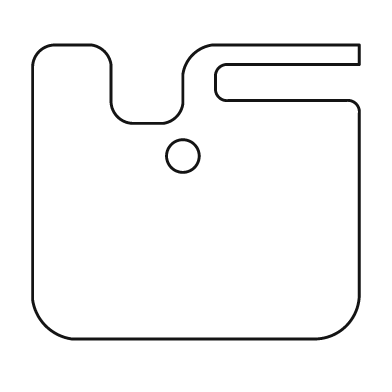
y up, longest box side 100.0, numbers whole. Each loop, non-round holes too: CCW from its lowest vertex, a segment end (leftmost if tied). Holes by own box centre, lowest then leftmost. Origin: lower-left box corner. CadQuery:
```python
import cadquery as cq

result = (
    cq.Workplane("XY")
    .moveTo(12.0, 0.0)
    .lineTo(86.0, 0.0)
    .threePointArc((96.0, 4.0), (100.0, 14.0))
    .lineTo(100.0, 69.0)
    .threePointArc((99.0, 72.0), (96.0, 73.0))
    .lineTo(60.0, 73.0)
    .threePointArc((57.0, 74.0), (56.0, 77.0))
    .lineTo(56.0, 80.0)
    .threePointArc((57.0, 83.0), (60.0, 84.0))
    .lineTo(100.0, 84.0)
    .lineTo(100.0, 90.0)
    .lineTo(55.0, 90.0)
    .threePointArc((49.0, 87.0), (46.0, 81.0))
    .lineTo(46.0, 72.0)
    .threePointArc((44.0, 68.0), (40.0, 66.0))
    .lineTo(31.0, 66.0)
    .threePointArc((26.0, 68.0), (24.0, 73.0))
    .lineTo(24.0, 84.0)
    .threePointArc((22.0, 88.0), (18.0, 90.0))
    .lineTo(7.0, 90.0)
    .threePointArc((2.0, 88.0), (0.0, 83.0))
    .lineTo(0.0, 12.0)
    .threePointArc((4.0, 4.0), (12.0, 0.0))
    .close()
    .moveTo(46.0, 56.0)
    .circle(5.0)
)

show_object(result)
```